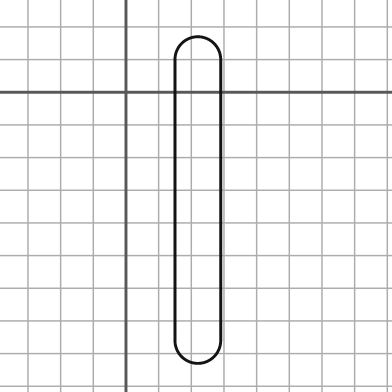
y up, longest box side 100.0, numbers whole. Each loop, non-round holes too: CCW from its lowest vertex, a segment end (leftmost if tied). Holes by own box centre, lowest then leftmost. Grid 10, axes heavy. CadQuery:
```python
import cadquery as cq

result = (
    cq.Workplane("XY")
    .moveTo(15.0, -76.0)
    .threePointArc((22.0, -83.0), (29.0, -76.0))
    .lineTo(29.0, 10.0)
    .threePointArc((22.0, 17.0), (15.0, 10.0))
    .close()
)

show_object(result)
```